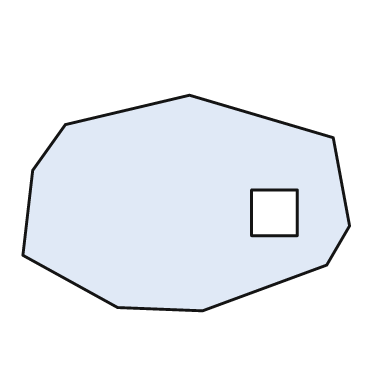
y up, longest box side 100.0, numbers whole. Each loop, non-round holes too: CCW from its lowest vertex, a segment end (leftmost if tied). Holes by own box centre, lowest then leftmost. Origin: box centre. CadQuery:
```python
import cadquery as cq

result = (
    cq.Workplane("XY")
    .moveTo(5.0, -33.0)
    .lineTo(43.0, -19.0)
    .lineTo(50.0, -7.0)
    .lineTo(45.0, 20.0)
    .lineTo(1.0, 33.0)
    .lineTo(-37.0, 24.0)
    .lineTo(-47.0, 10.0)
    .lineTo(-50.0, -16.0)
    .lineTo(-21.0, -32.0)
    .close()
    .moveTo(20.0, -10.0)
    .lineTo(34.0, -10.0)
    .lineTo(34.0, 4.0)
    .lineTo(20.0, 4.0)
    .close()
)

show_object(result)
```